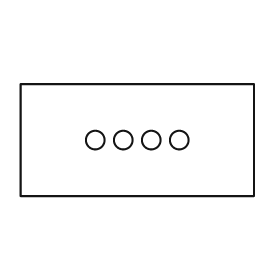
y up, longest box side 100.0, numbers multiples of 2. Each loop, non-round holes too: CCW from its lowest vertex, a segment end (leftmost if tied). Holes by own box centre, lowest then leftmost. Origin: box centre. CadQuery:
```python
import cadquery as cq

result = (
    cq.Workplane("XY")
    .moveTo(-50.0, -24.0)
    .lineTo(50.0, -24.0)
    .lineTo(50.0, 24.0)
    .lineTo(-50.0, 24.0)
    .close()
    .moveTo(-18.0, 0.0)
    .circle(4.0)
    .moveTo(-6.0, 0.0)
    .circle(4.0)
    .moveTo(6.0, 0.0)
    .circle(4.0)
    .moveTo(18.0, 0.0)
    .circle(4.0)
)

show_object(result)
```